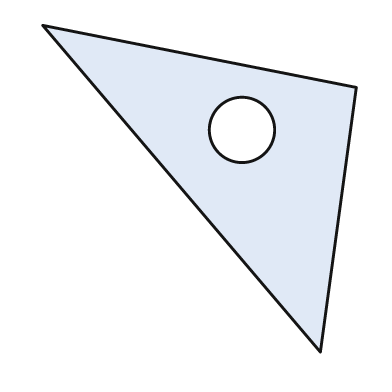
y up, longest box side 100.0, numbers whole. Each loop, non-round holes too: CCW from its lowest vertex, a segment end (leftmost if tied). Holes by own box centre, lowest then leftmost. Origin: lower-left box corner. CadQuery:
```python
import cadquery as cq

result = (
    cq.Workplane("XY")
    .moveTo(85.0, 0.0)
    .lineTo(96.0, 81.0)
    .lineTo(0.0, 100.0)
    .close()
    .moveTo(61.0, 68.0)
    .circle(10.0)
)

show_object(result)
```